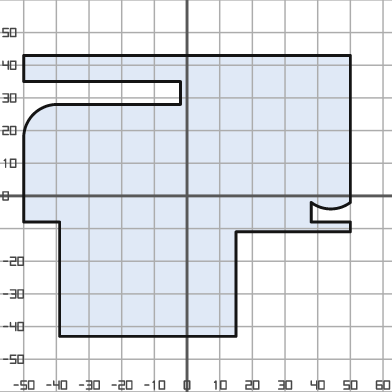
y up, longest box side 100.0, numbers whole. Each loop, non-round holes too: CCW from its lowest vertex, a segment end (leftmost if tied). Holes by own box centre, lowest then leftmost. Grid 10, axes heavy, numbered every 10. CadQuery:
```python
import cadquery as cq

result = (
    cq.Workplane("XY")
    .moveTo(-39.0, -43.0)
    .lineTo(15.0, -43.0)
    .lineTo(15.0, -11.0)
    .lineTo(50.0, -11.0)
    .lineTo(50.0, -8.0)
    .lineTo(38.0, -8.0)
    .lineTo(38.0, -2.0)
    .threePointArc((44.0, -4.0), (50.0, -2.0))
    .lineTo(50.0, 43.0)
    .lineTo(-50.0, 43.0)
    .lineTo(-50.0, 35.0)
    .lineTo(-2.0, 35.0)
    .lineTo(-2.0, 28.0)
    .lineTo(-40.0, 28.0)
    .threePointArc((-47.0, 25.0), (-50.0, 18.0))
    .lineTo(-50.0, -8.0)
    .lineTo(-39.0, -8.0)
    .close()
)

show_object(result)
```